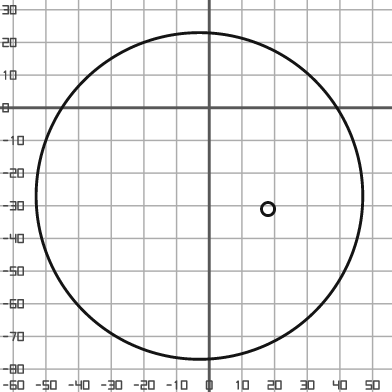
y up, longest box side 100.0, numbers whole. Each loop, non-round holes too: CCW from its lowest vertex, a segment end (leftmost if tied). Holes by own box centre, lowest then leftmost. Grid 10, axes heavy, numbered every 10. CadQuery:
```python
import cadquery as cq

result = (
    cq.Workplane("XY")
    .moveTo(-3.0, -27.0)
    .circle(50.0)
    .moveTo(18.0, -31.0)
    .circle(2.0)
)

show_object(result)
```